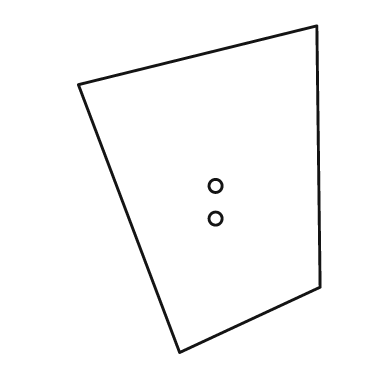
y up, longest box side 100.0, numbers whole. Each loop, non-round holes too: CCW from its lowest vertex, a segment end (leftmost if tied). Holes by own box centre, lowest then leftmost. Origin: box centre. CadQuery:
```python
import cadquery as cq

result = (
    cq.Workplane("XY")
    .moveTo(-6.0, -50.0)
    .lineTo(37.0, -30.0)
    .lineTo(36.0, 50.0)
    .lineTo(-37.0, 32.0)
    .close()
    .moveTo(5.0, -9.0)
    .circle(2.0)
    .moveTo(5.0, 1.0)
    .circle(2.0)
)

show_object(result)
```